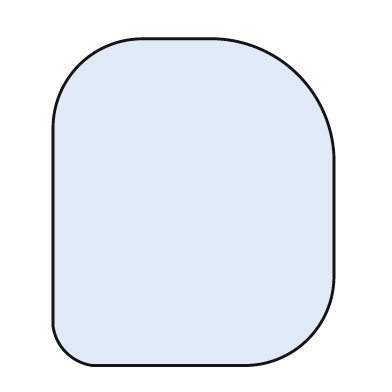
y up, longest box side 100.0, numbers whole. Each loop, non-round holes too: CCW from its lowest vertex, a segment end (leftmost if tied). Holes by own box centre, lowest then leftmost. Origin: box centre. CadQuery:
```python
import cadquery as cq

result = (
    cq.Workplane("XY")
    .moveTo(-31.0, -50.0)
    .lineTo(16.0, -50.0)
    .threePointArc((35.0, -42.0), (43.0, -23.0))
    .lineTo(43.0, 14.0)
    .threePointArc((32.0, 39.0), (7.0, 50.0))
    .lineTo(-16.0, 50.0)
    .threePointArc((-35.0, 42.0), (-43.0, 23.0))
    .lineTo(-43.0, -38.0)
    .threePointArc((-39.0, -46.0), (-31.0, -50.0))
    .close()
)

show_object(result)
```